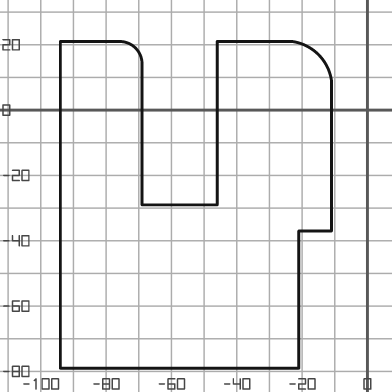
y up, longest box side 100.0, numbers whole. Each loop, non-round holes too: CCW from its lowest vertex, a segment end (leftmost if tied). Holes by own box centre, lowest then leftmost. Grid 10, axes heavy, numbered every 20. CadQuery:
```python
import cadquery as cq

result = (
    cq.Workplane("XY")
    .moveTo(-94.0, -79.0)
    .lineTo(-21.0, -79.0)
    .lineTo(-21.0, -37.0)
    .lineTo(-11.0, -37.0)
    .lineTo(-11.0, 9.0)
    .threePointArc((-15.0, 17.0), (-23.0, 21.0))
    .lineTo(-46.0, 21.0)
    .lineTo(-46.0, -29.0)
    .lineTo(-69.0, -29.0)
    .lineTo(-69.0, 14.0)
    .threePointArc((-71.0, 19.0), (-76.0, 21.0))
    .lineTo(-94.0, 21.0)
    .close()
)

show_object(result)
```